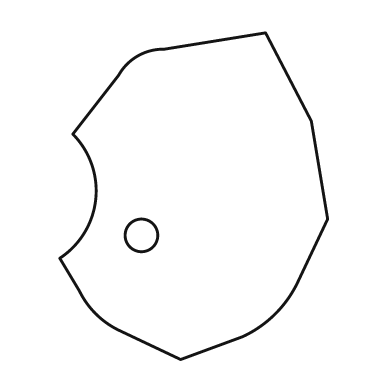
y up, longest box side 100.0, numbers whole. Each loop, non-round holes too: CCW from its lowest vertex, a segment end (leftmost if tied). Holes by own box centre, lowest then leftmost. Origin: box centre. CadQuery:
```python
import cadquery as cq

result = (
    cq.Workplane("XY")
    .moveTo(-4.0, -50.0)
    .lineTo(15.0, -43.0)
    .threePointArc((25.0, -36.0), (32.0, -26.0))
    .lineTo(41.0, -7.0)
    .lineTo(36.0, 23.0)
    .lineTo(22.0, 50.0)
    .lineTo(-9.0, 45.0)
    .threePointArc((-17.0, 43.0), (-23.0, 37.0))
    .lineTo(-37.0, 19.0)
    .threePointArc((-30.0, -1.0), (-41.0, -19.0))
    .lineTo(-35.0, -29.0)
    .threePointArc((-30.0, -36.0), (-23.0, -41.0))
    .close()
    .moveTo(-16.0, -12.0)
    .circle(5.0)
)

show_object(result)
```